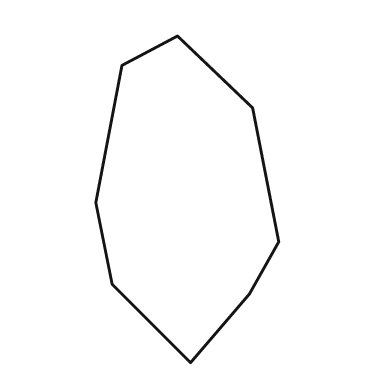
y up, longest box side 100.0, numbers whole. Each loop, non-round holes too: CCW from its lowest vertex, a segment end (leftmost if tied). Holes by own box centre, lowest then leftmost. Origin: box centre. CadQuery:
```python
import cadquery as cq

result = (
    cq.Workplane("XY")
    .moveTo(1.0, -50.0)
    .lineTo(19.0, -29.0)
    .lineTo(28.0, -13.0)
    .lineTo(20.0, 28.0)
    .lineTo(-3.0, 50.0)
    .lineTo(-20.0, 41.0)
    .lineTo(-28.0, -1.0)
    .lineTo(-23.0, -26.0)
    .close()
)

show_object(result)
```